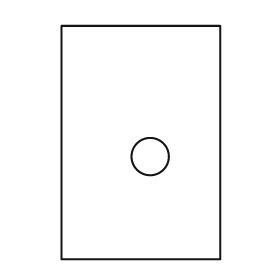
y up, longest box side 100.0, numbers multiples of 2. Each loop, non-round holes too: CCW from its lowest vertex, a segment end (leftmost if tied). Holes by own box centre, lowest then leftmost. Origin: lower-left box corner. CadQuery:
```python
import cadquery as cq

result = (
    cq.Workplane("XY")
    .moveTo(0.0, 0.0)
    .lineTo(68.0, 0.0)
    .lineTo(68.0, 100.0)
    .lineTo(0.0, 100.0)
    .close()
    .moveTo(38.0, 44.0)
    .circle(8.0)
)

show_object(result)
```